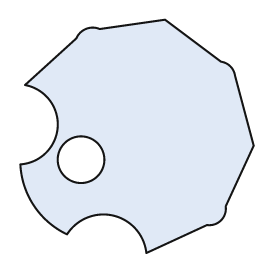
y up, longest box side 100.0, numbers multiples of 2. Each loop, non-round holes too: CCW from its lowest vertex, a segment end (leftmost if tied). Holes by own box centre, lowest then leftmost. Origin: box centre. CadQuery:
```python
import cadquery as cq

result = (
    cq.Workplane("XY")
    .moveTo(4.0, -50.0)
    .lineTo(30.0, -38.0)
    .threePointArc((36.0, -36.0), (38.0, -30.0))
    .lineTo(50.0, -4.0)
    .lineTo(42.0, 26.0)
    .threePointArc((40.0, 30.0), (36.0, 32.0))
    .lineTo(12.0, 50.0)
    .lineTo(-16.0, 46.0)
    .threePointArc((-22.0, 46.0), (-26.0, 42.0))
    .lineTo(-48.0, 22.0)
    .threePointArc((-34.0, 4.0), (-50.0, -12.0))
    .threePointArc((-44.0, -30.0), (-30.0, -42.0))
    .threePointArc((-10.0, -34.0), (4.0, -50.0))
    .close()
    .moveTo(-24.0, -10.0)
    .circle(10.0)
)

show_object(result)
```